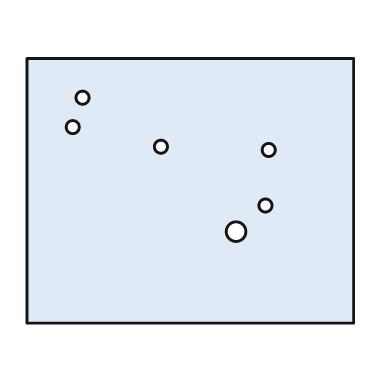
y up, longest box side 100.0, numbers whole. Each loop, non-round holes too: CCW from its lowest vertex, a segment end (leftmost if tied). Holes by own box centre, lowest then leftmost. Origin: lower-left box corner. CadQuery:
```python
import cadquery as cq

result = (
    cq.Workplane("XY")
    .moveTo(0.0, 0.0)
    .lineTo(100.0, 0.0)
    .lineTo(100.0, 81.0)
    .lineTo(0.0, 81.0)
    .close()
    .moveTo(64.0, 28.0)
    .circle(3.0)
    .moveTo(73.0, 36.0)
    .circle(2.0)
    .moveTo(74.0, 53.0)
    .circle(2.0)
    .moveTo(41.0, 54.0)
    .circle(2.0)
    .moveTo(14.0, 60.0)
    .circle(2.0)
    .moveTo(17.0, 69.0)
    .circle(2.0)
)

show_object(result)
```